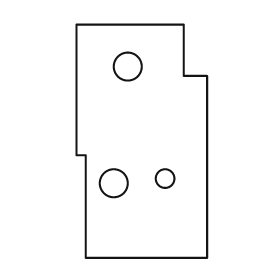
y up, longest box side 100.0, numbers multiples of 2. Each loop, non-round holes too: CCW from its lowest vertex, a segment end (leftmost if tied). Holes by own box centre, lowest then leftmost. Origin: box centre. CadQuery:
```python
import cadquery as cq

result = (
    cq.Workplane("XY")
    .moveTo(-24.0, -50.0)
    .lineTo(28.0, -50.0)
    .lineTo(28.0, 28.0)
    .lineTo(18.0, 28.0)
    .lineTo(18.0, 50.0)
    .lineTo(-28.0, 50.0)
    .lineTo(-28.0, -6.0)
    .lineTo(-24.0, -6.0)
    .close()
    .moveTo(-12.0, -18.0)
    .circle(6.0)
    .moveTo(10.0, -16.0)
    .circle(4.0)
    .moveTo(-6.0, 32.0)
    .circle(6.0)
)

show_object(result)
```